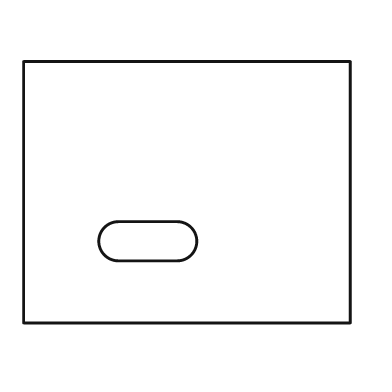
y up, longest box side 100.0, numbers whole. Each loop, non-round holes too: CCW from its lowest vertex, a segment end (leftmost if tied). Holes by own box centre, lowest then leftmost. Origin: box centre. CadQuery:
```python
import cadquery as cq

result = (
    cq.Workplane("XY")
    .moveTo(-50.0, -40.0)
    .lineTo(50.0, -40.0)
    .lineTo(50.0, 40.0)
    .lineTo(-50.0, 40.0)
    .close()
    .moveTo(-21.0, -21.0)
    .lineTo(-3.0, -21.0)
    .threePointArc((3.0, -15.0), (-3.0, -9.0))
    .lineTo(-21.0, -9.0)
    .threePointArc((-27.0, -15.0), (-21.0, -21.0))
    .close()
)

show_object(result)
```